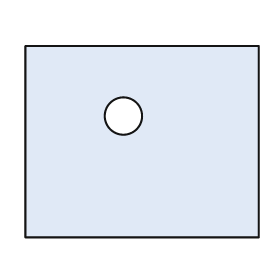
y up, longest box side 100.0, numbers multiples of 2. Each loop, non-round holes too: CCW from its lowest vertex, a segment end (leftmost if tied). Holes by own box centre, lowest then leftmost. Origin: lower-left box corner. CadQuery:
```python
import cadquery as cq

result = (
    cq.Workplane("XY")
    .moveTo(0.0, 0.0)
    .lineTo(100.0, 0.0)
    .lineTo(100.0, 82.0)
    .lineTo(0.0, 82.0)
    .close()
    .moveTo(42.0, 52.0)
    .circle(8.0)
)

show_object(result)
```